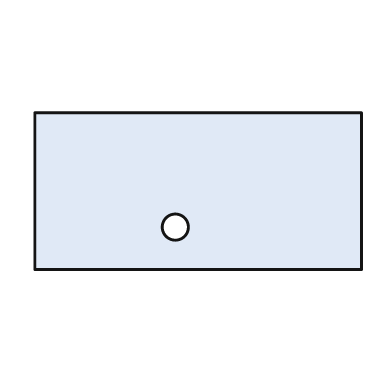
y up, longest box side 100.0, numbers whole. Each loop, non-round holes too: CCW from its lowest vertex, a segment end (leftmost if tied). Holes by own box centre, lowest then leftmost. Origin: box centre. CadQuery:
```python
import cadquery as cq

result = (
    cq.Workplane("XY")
    .moveTo(-50.0, -24.0)
    .lineTo(50.0, -24.0)
    .lineTo(50.0, 24.0)
    .lineTo(-50.0, 24.0)
    .close()
    .moveTo(-7.0, -11.0)
    .circle(4.0)
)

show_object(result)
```